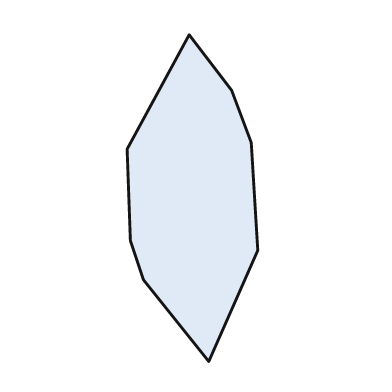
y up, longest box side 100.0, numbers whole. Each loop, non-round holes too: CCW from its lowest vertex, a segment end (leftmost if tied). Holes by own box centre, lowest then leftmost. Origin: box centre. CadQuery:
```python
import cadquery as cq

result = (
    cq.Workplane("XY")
    .moveTo(5.0, -50.0)
    .lineTo(20.0, -16.0)
    .lineTo(18.0, 17.0)
    .lineTo(12.0, 33.0)
    .lineTo(-1.0, 50.0)
    .lineTo(-20.0, 15.0)
    .lineTo(-19.0, -13.0)
    .lineTo(-15.0, -25.0)
    .close()
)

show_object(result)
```